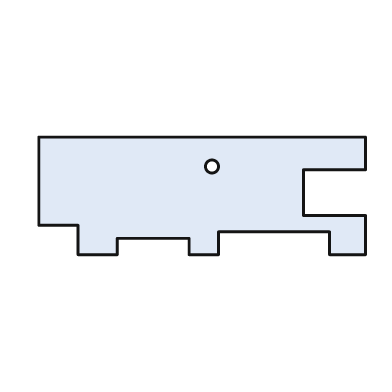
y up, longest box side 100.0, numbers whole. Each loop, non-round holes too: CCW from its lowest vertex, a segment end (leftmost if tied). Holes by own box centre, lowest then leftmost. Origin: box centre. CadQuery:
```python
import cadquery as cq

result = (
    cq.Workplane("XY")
    .moveTo(-38.0, -18.0)
    .lineTo(-26.0, -18.0)
    .lineTo(-26.0, -13.0)
    .lineTo(-4.0, -13.0)
    .lineTo(-4.0, -18.0)
    .lineTo(5.0, -18.0)
    .lineTo(5.0, -11.0)
    .lineTo(39.0, -11.0)
    .lineTo(39.0, -18.0)
    .lineTo(50.0, -18.0)
    .lineTo(50.0, -6.0)
    .lineTo(31.0, -6.0)
    .lineTo(31.0, 8.0)
    .lineTo(50.0, 8.0)
    .lineTo(50.0, 18.0)
    .lineTo(-50.0, 18.0)
    .lineTo(-50.0, -9.0)
    .lineTo(-38.0, -9.0)
    .close()
    .moveTo(3.0, 9.0)
    .circle(2.0)
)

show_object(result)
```